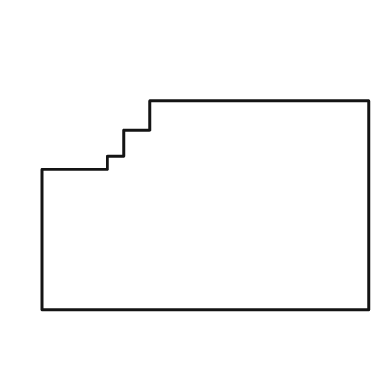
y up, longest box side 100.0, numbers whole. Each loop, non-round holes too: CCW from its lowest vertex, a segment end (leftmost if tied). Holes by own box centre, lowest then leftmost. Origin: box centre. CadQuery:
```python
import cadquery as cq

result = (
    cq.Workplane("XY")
    .moveTo(-50.0, -32.0)
    .lineTo(50.0, -32.0)
    .lineTo(50.0, 32.0)
    .lineTo(-17.0, 32.0)
    .lineTo(-17.0, 23.0)
    .lineTo(-25.0, 23.0)
    .lineTo(-25.0, 15.0)
    .lineTo(-30.0, 15.0)
    .lineTo(-30.0, 11.0)
    .lineTo(-50.0, 11.0)
    .close()
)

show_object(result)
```